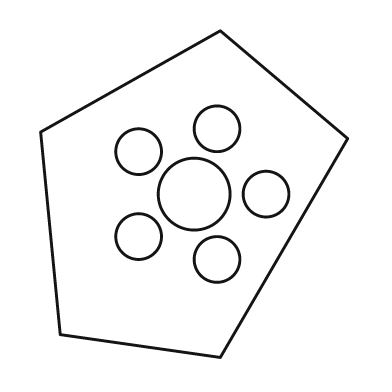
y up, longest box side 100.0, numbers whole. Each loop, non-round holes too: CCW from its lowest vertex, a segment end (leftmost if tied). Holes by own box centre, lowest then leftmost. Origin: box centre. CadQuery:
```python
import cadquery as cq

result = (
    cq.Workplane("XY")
    .moveTo(8.0, -50.0)
    .lineTo(47.0, 17.0)
    .lineTo(8.0, 50.0)
    .lineTo(-47.0, 19.0)
    .lineTo(-41.0, -43.0)
    .close()
    .moveTo(7.0, -20.0)
    .circle(7.0)
    .moveTo(-17.0, -13.0)
    .circle(7.0)
    .moveTo(0.0, 0.0)
    .circle(11.0)
    .moveTo(22.0, 0.0)
    .circle(7.0)
    .moveTo(-17.0, 13.0)
    .circle(7.0)
    .moveTo(7.0, 20.0)
    .circle(7.0)
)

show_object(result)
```